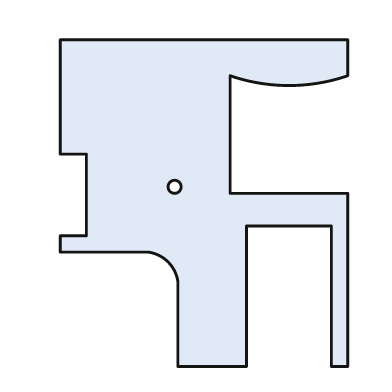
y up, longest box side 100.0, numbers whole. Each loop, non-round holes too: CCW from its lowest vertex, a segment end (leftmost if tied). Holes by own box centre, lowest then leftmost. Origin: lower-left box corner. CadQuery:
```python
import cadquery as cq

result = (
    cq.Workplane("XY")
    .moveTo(36.0, 0.0)
    .lineTo(57.0, 0.0)
    .lineTo(57.0, 43.0)
    .lineTo(83.0, 43.0)
    .lineTo(83.0, 0.0)
    .lineTo(88.0, 0.0)
    .lineTo(88.0, 53.0)
    .lineTo(52.0, 53.0)
    .lineTo(52.0, 89.0)
    .threePointArc((70.0, 86.0), (88.0, 89.0))
    .lineTo(88.0, 100.0)
    .lineTo(0.0, 100.0)
    .lineTo(0.0, 65.0)
    .lineTo(8.0, 65.0)
    .lineTo(8.0, 40.0)
    .lineTo(0.0, 40.0)
    .lineTo(0.0, 35.0)
    .lineTo(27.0, 35.0)
    .threePointArc((33.0, 32.0), (36.0, 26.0))
    .close()
    .moveTo(35.0, 55.0)
    .circle(2.0)
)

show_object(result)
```